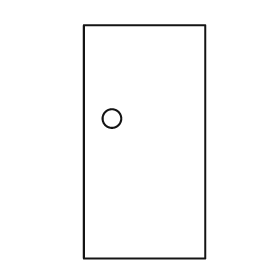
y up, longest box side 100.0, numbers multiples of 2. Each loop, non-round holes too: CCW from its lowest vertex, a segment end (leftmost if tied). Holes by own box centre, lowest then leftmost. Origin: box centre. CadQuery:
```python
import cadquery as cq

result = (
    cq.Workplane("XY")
    .moveTo(-26.0, -50.0)
    .lineTo(26.0, -50.0)
    .lineTo(26.0, 50.0)
    .lineTo(-26.0, 50.0)
    .close()
    .moveTo(-14.0, 10.0)
    .circle(4.0)
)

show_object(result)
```